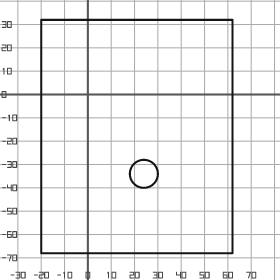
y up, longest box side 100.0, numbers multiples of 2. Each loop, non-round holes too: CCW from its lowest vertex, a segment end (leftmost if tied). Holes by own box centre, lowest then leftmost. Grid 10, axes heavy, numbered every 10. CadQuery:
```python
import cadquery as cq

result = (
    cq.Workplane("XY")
    .moveTo(-20.0, -68.0)
    .lineTo(62.0, -68.0)
    .lineTo(62.0, 32.0)
    .lineTo(-20.0, 32.0)
    .close()
    .moveTo(24.0, -34.0)
    .circle(6.0)
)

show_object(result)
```